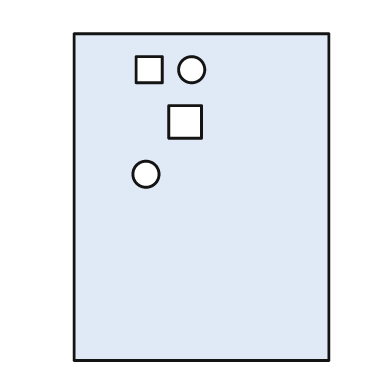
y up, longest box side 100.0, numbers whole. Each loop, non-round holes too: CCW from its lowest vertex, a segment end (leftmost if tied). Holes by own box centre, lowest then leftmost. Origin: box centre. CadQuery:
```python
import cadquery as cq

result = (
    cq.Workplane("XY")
    .moveTo(-39.0, -50.0)
    .lineTo(39.0, -50.0)
    .lineTo(39.0, 50.0)
    .lineTo(-39.0, 50.0)
    .close()
    .moveTo(-17.0, 7.0)
    .circle(4.0)
    .moveTo(-10.0, 18.0)
    .lineTo(0.0, 18.0)
    .lineTo(0.0, 28.0)
    .lineTo(-10.0, 28.0)
    .close()
    .moveTo(-20.0, 35.0)
    .lineTo(-12.0, 35.0)
    .lineTo(-12.0, 43.0)
    .lineTo(-20.0, 43.0)
    .close()
    .moveTo(-3.0, 39.0)
    .circle(4.0)
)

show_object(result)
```